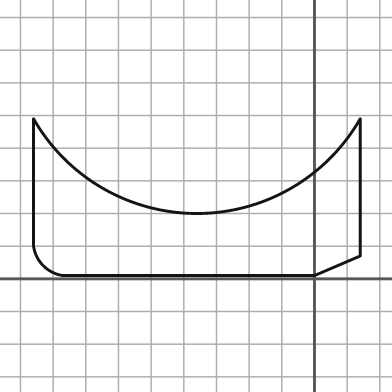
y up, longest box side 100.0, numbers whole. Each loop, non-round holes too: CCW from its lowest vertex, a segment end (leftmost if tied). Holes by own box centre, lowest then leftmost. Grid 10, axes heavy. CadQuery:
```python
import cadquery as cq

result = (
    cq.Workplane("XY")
    .moveTo(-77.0, 1.0)
    .lineTo(0.0, 1.0)
    .lineTo(14.0, 7.0)
    .lineTo(14.0, 49.0)
    .threePointArc((-36.0, 20.0), (-86.0, 49.0))
    .lineTo(-86.0, 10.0)
    .threePointArc((-83.0, 4.0), (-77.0, 1.0))
    .close()
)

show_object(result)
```